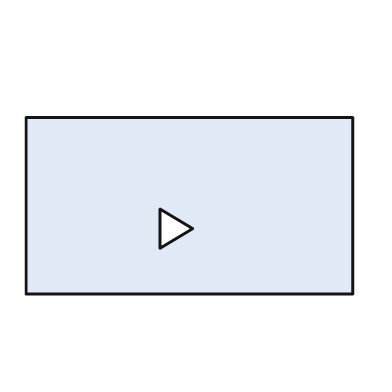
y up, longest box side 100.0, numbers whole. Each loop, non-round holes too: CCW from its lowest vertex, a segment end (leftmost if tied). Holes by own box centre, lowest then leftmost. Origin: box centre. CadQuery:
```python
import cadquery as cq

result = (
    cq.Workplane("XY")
    .moveTo(-50.0, -27.0)
    .lineTo(50.0, -27.0)
    .lineTo(50.0, 27.0)
    .lineTo(-50.0, 27.0)
    .close()
    .moveTo(-9.0, -13.0)
    .lineTo(1.0, -7.0)
    .lineTo(-9.0, -1.0)
    .close()
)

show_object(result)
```